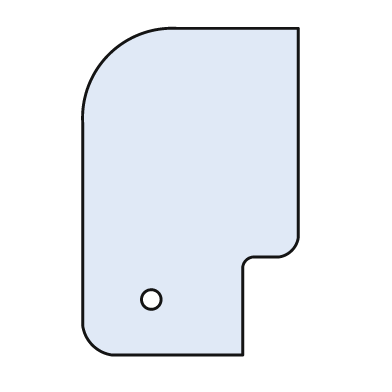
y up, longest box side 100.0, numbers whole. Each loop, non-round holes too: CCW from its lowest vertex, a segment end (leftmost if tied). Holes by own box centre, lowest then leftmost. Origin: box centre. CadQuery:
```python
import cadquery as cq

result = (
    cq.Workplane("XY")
    .moveTo(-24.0, -50.0)
    .lineTo(16.0, -50.0)
    .lineTo(16.0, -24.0)
    .threePointArc((17.0, -21.0), (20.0, -20.0))
    .lineTo(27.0, -20.0)
    .threePointArc((31.0, -18.0), (33.0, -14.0))
    .lineTo(33.0, 50.0)
    .lineTo(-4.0, 50.0)
    .threePointArc((-25.0, 42.0), (-33.0, 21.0))
    .lineTo(-33.0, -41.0)
    .threePointArc((-30.0, -47.0), (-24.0, -50.0))
    .close()
    .moveTo(-12.0, -33.0)
    .circle(3.0)
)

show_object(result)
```